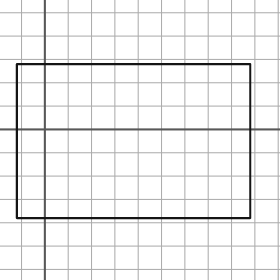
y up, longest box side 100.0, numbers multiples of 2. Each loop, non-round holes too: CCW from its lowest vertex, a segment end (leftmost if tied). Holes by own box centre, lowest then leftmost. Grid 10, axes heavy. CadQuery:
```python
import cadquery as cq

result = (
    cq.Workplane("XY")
    .moveTo(-12.0, -38.0)
    .lineTo(88.0, -38.0)
    .lineTo(88.0, 28.0)
    .lineTo(-12.0, 28.0)
    .close()
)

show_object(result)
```